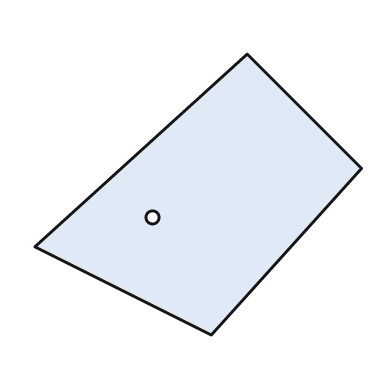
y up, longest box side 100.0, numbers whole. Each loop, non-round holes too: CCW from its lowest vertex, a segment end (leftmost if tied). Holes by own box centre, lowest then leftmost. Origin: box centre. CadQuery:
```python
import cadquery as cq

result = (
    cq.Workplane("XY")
    .moveTo(4.0, -43.0)
    .lineTo(50.0, 8.0)
    .lineTo(15.0, 43.0)
    .lineTo(-50.0, -16.0)
    .close()
    .moveTo(-14.0, -7.0)
    .circle(2.0)
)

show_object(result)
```